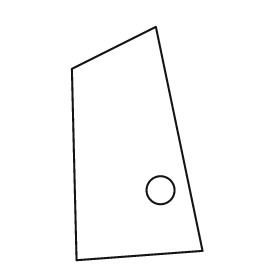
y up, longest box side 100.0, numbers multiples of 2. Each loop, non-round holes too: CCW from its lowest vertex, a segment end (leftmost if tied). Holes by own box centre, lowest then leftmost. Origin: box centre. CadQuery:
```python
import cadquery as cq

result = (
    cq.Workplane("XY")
    .moveTo(-26.0, -50.0)
    .lineTo(28.0, -46.0)
    .lineTo(8.0, 50.0)
    .lineTo(-28.0, 32.0)
    .close()
    .moveTo(10.0, -20.0)
    .circle(6.0)
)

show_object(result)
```